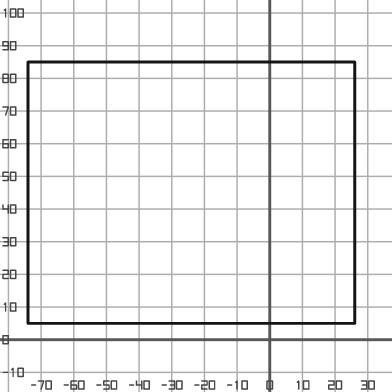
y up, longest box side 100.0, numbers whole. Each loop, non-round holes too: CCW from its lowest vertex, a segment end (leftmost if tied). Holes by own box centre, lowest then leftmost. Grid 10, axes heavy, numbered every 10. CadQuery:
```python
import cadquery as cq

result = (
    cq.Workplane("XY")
    .moveTo(-74.0, 5.0)
    .lineTo(26.0, 5.0)
    .lineTo(26.0, 85.0)
    .lineTo(-74.0, 85.0)
    .close()
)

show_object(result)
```